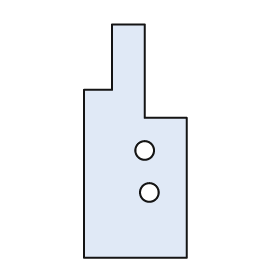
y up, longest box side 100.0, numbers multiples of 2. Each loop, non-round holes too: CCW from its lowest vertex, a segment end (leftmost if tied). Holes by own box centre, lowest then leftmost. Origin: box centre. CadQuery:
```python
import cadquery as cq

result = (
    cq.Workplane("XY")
    .moveTo(-22.0, -50.0)
    .lineTo(22.0, -50.0)
    .lineTo(22.0, 10.0)
    .lineTo(4.0, 10.0)
    .lineTo(4.0, 50.0)
    .lineTo(-10.0, 50.0)
    .lineTo(-10.0, 22.0)
    .lineTo(-22.0, 22.0)
    .close()
    .moveTo(6.0, -22.0)
    .circle(4.0)
    .moveTo(4.0, -4.0)
    .circle(4.0)
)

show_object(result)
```